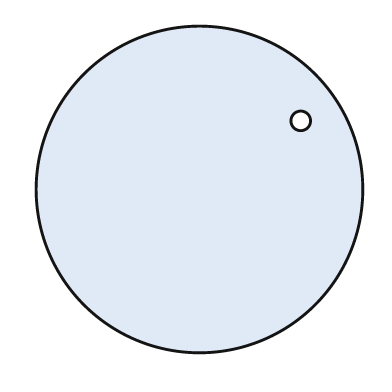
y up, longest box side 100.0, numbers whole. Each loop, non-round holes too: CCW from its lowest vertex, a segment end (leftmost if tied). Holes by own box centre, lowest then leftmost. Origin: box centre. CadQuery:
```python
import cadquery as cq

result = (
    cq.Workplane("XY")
    .moveTo(0.0, 0.0)
    .circle(50.0)
    .moveTo(31.0, 21.0)
    .circle(3.0)
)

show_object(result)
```